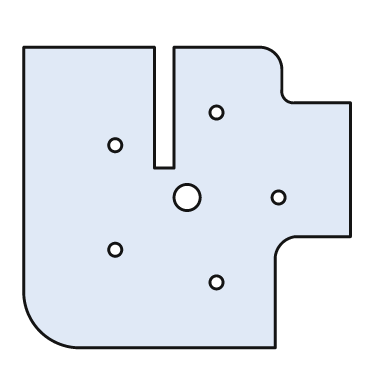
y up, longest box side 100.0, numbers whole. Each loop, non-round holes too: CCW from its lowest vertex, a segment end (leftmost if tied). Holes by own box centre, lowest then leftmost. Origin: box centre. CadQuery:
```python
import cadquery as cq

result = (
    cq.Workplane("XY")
    .moveTo(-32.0, -46.0)
    .lineTo(27.0, -46.0)
    .lineTo(27.0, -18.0)
    .threePointArc((29.0, -14.0), (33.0, -12.0))
    .lineTo(50.0, -12.0)
    .lineTo(50.0, 29.0)
    .lineTo(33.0, 29.0)
    .threePointArc((30.0, 30.0), (29.0, 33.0))
    .lineTo(29.0, 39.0)
    .threePointArc((27.0, 44.0), (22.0, 46.0))
    .lineTo(-4.0, 46.0)
    .lineTo(-4.0, 9.0)
    .lineTo(-10.0, 9.0)
    .lineTo(-10.0, 46.0)
    .lineTo(-50.0, 46.0)
    .lineTo(-50.0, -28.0)
    .threePointArc((-45.0, -41.0), (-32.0, -46.0))
    .close()
    .moveTo(9.0, -26.0)
    .circle(2.0)
    .moveTo(-22.0, -16.0)
    .circle(2.0)
    .moveTo(0.0, 0.0)
    .circle(4.0)
    .moveTo(28.0, 0.0)
    .circle(2.0)
    .moveTo(-22.0, 16.0)
    .circle(2.0)
    .moveTo(9.0, 26.0)
    .circle(2.0)
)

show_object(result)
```